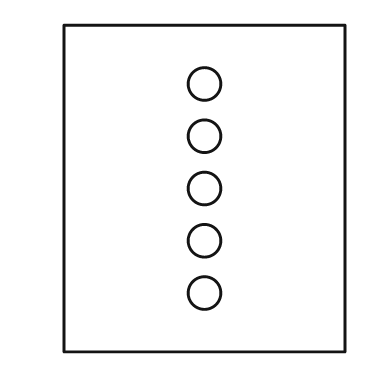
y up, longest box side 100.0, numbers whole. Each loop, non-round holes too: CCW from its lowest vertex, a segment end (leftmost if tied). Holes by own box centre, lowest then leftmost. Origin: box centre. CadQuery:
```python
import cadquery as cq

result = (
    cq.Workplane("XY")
    .moveTo(-43.0, -50.0)
    .lineTo(43.0, -50.0)
    .lineTo(43.0, 50.0)
    .lineTo(-43.0, 50.0)
    .close()
    .moveTo(0.0, -32.0)
    .circle(5.0)
    .moveTo(0.0, -16.0)
    .circle(5.0)
    .moveTo(0.0, 0.0)
    .circle(5.0)
    .moveTo(0.0, 16.0)
    .circle(5.0)
    .moveTo(0.0, 32.0)
    .circle(5.0)
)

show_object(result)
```